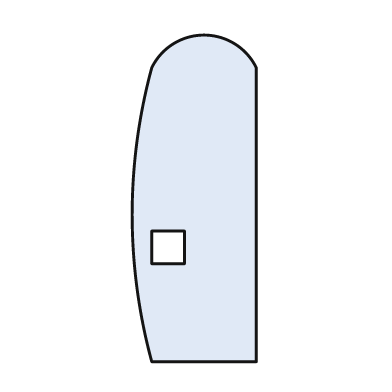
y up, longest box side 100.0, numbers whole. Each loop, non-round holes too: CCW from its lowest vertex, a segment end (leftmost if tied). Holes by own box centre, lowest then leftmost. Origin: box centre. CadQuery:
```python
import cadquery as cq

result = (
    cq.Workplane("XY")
    .moveTo(-13.0, -50.0)
    .lineTo(19.0, -50.0)
    .lineTo(19.0, 40.0)
    .threePointArc((3.0, 50.0), (-13.0, 40.0))
    .threePointArc((-19.0, -5.0), (-13.0, -50.0))
    .close()
    .moveTo(-13.0, -20.0)
    .lineTo(-3.0, -20.0)
    .lineTo(-3.0, -10.0)
    .lineTo(-13.0, -10.0)
    .close()
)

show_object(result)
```